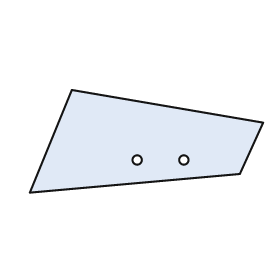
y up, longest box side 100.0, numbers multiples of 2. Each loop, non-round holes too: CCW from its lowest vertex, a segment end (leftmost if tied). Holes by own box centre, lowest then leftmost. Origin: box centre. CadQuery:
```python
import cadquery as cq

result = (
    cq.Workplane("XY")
    .moveTo(-50.0, -22.0)
    .lineTo(40.0, -14.0)
    .lineTo(50.0, 8.0)
    .lineTo(-32.0, 22.0)
    .close()
    .moveTo(-4.0, -8.0)
    .circle(2.0)
    .moveTo(16.0, -8.0)
    .circle(2.0)
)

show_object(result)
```